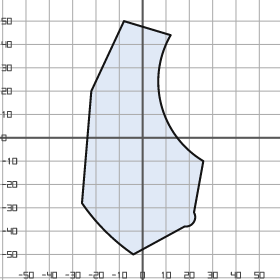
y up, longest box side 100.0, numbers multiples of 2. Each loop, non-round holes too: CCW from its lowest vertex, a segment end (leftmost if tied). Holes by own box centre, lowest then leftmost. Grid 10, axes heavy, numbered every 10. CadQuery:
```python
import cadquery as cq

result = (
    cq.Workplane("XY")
    .moveTo(-4.0, -50.0)
    .lineTo(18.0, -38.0)
    .threePointArc((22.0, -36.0), (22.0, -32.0))
    .lineTo(26.0, -10.0)
    .threePointArc((8.0, 14.0), (12.0, 44.0))
    .lineTo(-8.0, 50.0)
    .lineTo(-22.0, 20.0)
    .lineTo(-26.0, -28.0)
    .threePointArc((-16.0, -40.0), (-4.0, -50.0))
    .close()
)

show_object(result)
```